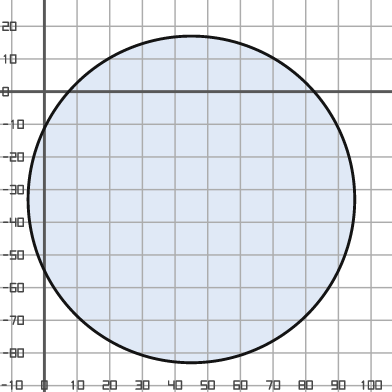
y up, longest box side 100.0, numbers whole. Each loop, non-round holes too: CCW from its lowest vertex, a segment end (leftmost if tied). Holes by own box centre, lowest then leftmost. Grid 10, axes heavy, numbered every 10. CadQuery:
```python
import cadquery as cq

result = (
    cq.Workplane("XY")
    .moveTo(45.0, -33.0)
    .circle(50.0)
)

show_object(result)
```